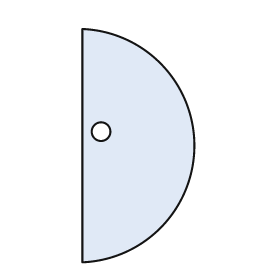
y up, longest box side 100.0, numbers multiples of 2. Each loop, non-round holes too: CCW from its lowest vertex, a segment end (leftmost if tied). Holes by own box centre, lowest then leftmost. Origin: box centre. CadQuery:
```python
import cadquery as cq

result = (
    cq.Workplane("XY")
    .moveTo(-24.0, -50.0)
    .threePointArc((24.0, 0.0), (-24.0, 50.0))
    .close()
    .moveTo(-16.0, 6.0)
    .circle(4.0)
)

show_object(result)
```